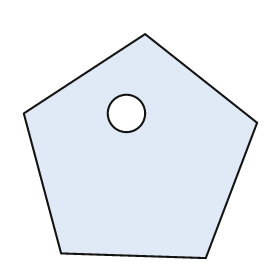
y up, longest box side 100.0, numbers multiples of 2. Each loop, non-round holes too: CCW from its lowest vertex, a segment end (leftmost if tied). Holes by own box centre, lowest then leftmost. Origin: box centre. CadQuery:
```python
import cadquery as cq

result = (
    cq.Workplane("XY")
    .moveTo(28.0, -48.0)
    .lineTo(50.0, 10.0)
    .lineTo(2.0, 48.0)
    .lineTo(-50.0, 14.0)
    .lineTo(-34.0, -46.0)
    .close()
    .moveTo(-6.0, 14.0)
    .circle(8.0)
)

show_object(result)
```